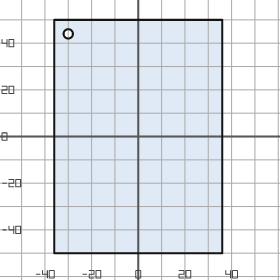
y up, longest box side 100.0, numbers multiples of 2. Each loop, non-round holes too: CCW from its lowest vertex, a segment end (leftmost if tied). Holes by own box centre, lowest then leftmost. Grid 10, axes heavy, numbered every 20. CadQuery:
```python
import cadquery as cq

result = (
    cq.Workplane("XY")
    .moveTo(-36.0, -50.0)
    .lineTo(36.0, -50.0)
    .lineTo(36.0, 50.0)
    .lineTo(-36.0, 50.0)
    .close()
    .moveTo(-30.0, 44.0)
    .circle(2.0)
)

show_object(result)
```